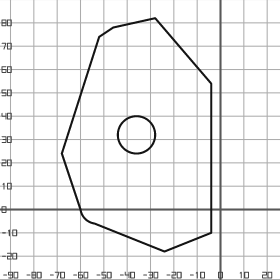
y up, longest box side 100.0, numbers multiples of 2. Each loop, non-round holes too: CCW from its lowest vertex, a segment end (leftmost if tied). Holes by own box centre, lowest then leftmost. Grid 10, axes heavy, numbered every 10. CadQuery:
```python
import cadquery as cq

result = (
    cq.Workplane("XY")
    .moveTo(-24.0, -18.0)
    .lineTo(-4.0, -10.0)
    .lineTo(-4.0, 54.0)
    .lineTo(-28.0, 82.0)
    .lineTo(-46.0, 78.0)
    .lineTo(-52.0, 74.0)
    .lineTo(-68.0, 24.0)
    .lineTo(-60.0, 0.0)
    .threePointArc((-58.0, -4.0), (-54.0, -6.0))
    .close()
    .moveTo(-36.0, 32.0)
    .circle(8.0)
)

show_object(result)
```